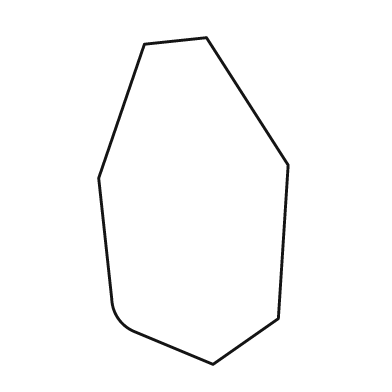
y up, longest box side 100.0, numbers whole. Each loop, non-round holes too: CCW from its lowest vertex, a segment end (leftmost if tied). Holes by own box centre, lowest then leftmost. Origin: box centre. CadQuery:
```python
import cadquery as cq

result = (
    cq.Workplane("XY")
    .moveTo(6.0, -50.0)
    .lineTo(26.0, -36.0)
    .lineTo(29.0, 11.0)
    .lineTo(4.0, 50.0)
    .lineTo(-15.0, 48.0)
    .lineTo(-29.0, 7.0)
    .lineTo(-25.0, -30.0)
    .threePointArc((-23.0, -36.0), (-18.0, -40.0))
    .close()
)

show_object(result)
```